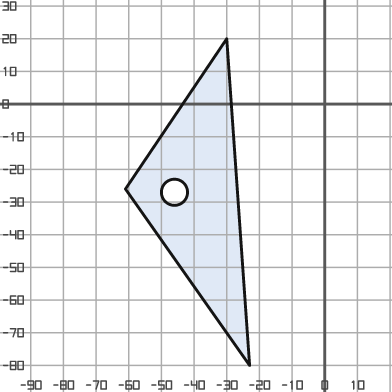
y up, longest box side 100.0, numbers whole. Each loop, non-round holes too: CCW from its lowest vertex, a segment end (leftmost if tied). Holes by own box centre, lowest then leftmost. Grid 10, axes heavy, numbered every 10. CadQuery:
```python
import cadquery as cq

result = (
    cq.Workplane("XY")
    .moveTo(-23.0, -80.0)
    .lineTo(-30.0, 20.0)
    .lineTo(-61.0, -26.0)
    .close()
    .moveTo(-46.0, -27.0)
    .circle(4.0)
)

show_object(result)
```